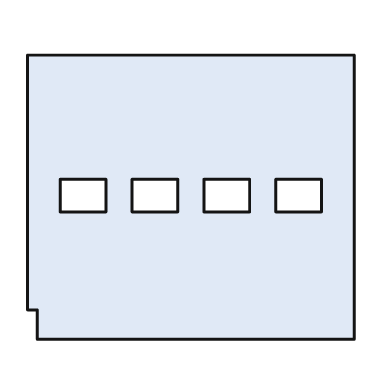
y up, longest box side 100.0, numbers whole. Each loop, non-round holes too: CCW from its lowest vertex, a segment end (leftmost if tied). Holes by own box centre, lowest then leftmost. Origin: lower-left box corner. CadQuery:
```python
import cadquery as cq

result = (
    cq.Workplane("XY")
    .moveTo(3.0, 0.0)
    .lineTo(100.0, 0.0)
    .lineTo(100.0, 87.0)
    .lineTo(0.0, 87.0)
    .lineTo(0.0, 9.0)
    .lineTo(3.0, 9.0)
    .close()
    .moveTo(10.0, 39.0)
    .lineTo(24.0, 39.0)
    .lineTo(24.0, 49.0)
    .lineTo(10.0, 49.0)
    .close()
    .moveTo(32.0, 39.0)
    .lineTo(46.0, 39.0)
    .lineTo(46.0, 49.0)
    .lineTo(32.0, 49.0)
    .close()
    .moveTo(54.0, 39.0)
    .lineTo(68.0, 39.0)
    .lineTo(68.0, 49.0)
    .lineTo(54.0, 49.0)
    .close()
    .moveTo(76.0, 39.0)
    .lineTo(90.0, 39.0)
    .lineTo(90.0, 49.0)
    .lineTo(76.0, 49.0)
    .close()
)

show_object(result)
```